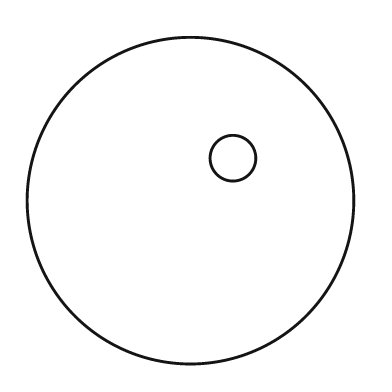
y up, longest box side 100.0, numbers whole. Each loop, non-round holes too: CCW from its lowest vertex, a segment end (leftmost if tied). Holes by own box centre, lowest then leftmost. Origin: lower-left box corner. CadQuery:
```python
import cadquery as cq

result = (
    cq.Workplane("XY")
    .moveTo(50.0, 50.0)
    .circle(50.0)
    .moveTo(63.0, 63.0)
    .circle(7.0)
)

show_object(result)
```